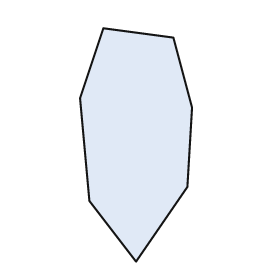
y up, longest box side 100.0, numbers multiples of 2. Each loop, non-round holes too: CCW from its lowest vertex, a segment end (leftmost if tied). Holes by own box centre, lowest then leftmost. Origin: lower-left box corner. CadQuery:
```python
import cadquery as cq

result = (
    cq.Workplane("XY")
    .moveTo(24.0, 0.0)
    .lineTo(46.0, 32.0)
    .lineTo(48.0, 66.0)
    .lineTo(40.0, 96.0)
    .lineTo(10.0, 100.0)
    .lineTo(0.0, 70.0)
    .lineTo(4.0, 26.0)
    .close()
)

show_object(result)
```